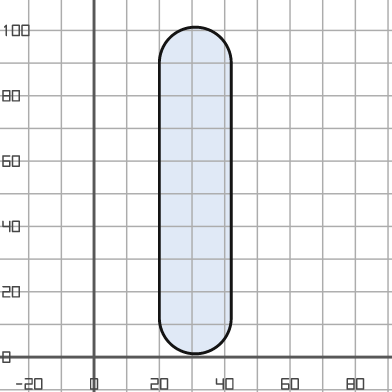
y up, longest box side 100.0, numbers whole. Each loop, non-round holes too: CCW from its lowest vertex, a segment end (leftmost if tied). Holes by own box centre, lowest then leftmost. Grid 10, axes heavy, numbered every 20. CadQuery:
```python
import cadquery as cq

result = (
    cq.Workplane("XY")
    .moveTo(20.0, 12.0)
    .threePointArc((31.0, 1.0), (42.0, 12.0))
    .lineTo(42.0, 90.0)
    .threePointArc((31.0, 101.0), (20.0, 90.0))
    .close()
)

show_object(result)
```